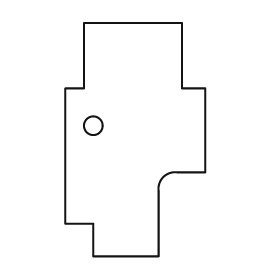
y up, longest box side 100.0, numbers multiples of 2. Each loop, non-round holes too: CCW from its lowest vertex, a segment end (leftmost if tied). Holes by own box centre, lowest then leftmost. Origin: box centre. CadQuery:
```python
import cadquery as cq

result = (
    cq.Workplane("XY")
    .moveTo(-18.0, -50.0)
    .lineTo(10.0, -50.0)
    .lineTo(10.0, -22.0)
    .threePointArc((12.0, -16.0), (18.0, -14.0))
    .lineTo(30.0, -14.0)
    .lineTo(30.0, 22.0)
    .lineTo(20.0, 22.0)
    .lineTo(20.0, 50.0)
    .lineTo(-22.0, 50.0)
    .lineTo(-22.0, 22.0)
    .lineTo(-30.0, 22.0)
    .lineTo(-30.0, -36.0)
    .lineTo(-18.0, -36.0)
    .close()
    .moveTo(-18.0, 6.0)
    .circle(4.0)
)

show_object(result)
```